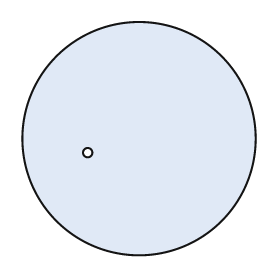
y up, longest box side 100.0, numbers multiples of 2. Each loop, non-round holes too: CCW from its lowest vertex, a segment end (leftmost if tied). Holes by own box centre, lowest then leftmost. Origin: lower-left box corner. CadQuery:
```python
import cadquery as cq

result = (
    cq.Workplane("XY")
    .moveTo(50.0, 50.0)
    .circle(50.0)
    .moveTo(28.0, 44.0)
    .circle(2.0)
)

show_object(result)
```